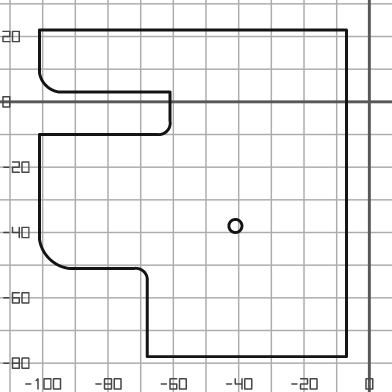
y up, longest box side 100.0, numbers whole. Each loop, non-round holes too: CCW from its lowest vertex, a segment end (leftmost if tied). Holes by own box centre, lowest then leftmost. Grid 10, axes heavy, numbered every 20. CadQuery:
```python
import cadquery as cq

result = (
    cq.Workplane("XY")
    .moveTo(-68.0, -78.0)
    .lineTo(-7.0, -78.0)
    .lineTo(-7.0, 22.0)
    .lineTo(-101.0, 22.0)
    .lineTo(-101.0, 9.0)
    .threePointArc((-99.0, 5.0), (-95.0, 3.0))
    .lineTo(-61.0, 3.0)
    .lineTo(-61.0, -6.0)
    .threePointArc((-62.0, -9.0), (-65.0, -10.0))
    .lineTo(-101.0, -10.0)
    .lineTo(-101.0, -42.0)
    .threePointArc((-98.0, -48.0), (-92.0, -51.0))
    .lineTo(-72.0, -51.0)
    .threePointArc((-69.0, -52.0), (-68.0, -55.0))
    .close()
    .moveTo(-41.0, -38.0)
    .circle(2.0)
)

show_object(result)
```